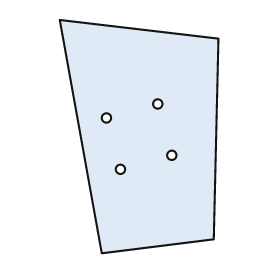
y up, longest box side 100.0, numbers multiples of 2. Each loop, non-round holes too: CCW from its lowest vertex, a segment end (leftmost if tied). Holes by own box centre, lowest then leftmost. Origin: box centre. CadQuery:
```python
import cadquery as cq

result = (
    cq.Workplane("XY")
    .moveTo(-16.0, -50.0)
    .lineTo(32.0, -44.0)
    .lineTo(34.0, 42.0)
    .lineTo(-34.0, 50.0)
    .close()
    .moveTo(-8.0, -14.0)
    .circle(2.0)
    .moveTo(14.0, -8.0)
    .circle(2.0)
    .moveTo(-14.0, 8.0)
    .circle(2.0)
    .moveTo(8.0, 14.0)
    .circle(2.0)
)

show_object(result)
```